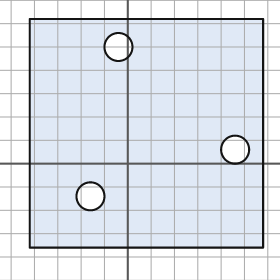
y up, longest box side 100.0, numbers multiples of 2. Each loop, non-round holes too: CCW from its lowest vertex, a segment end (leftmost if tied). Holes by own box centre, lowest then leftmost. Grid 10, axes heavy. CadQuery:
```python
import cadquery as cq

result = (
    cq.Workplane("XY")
    .moveTo(-42.0, -36.0)
    .lineTo(58.0, -36.0)
    .lineTo(58.0, 62.0)
    .lineTo(-42.0, 62.0)
    .close()
    .moveTo(-16.0, -14.0)
    .circle(6.0)
    .moveTo(46.0, 6.0)
    .circle(6.0)
    .moveTo(-4.0, 50.0)
    .circle(6.0)
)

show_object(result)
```